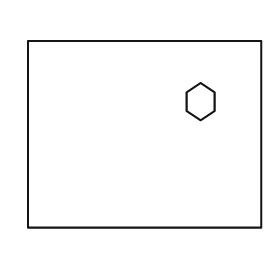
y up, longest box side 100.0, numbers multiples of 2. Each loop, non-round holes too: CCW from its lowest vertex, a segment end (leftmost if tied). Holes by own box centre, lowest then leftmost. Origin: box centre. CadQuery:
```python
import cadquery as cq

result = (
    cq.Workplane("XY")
    .moveTo(-50.0, -40.0)
    .lineTo(50.0, -40.0)
    .lineTo(50.0, 40.0)
    .lineTo(-50.0, 40.0)
    .close()
    .moveTo(24.0, 6.0)
    .lineTo(30.0, 10.0)
    .lineTo(30.0, 18.0)
    .lineTo(24.0, 22.0)
    .lineTo(18.0, 18.0)
    .lineTo(18.0, 10.0)
    .close()
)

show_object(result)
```